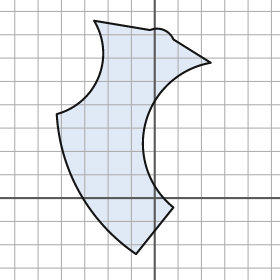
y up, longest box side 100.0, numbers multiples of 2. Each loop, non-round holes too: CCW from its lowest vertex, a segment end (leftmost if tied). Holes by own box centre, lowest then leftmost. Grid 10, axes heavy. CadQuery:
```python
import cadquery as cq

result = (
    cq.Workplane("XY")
    .moveTo(-8.0, -24.0)
    .lineTo(8.0, -4.0)
    .threePointArc((-4.0, 32.0), (24.0, 58.0))
    .lineTo(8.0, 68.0)
    .threePointArc((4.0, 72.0), (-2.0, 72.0))
    .lineTo(-26.0, 76.0)
    .threePointArc((-24.0, 52.0), (-42.0, 36.0))
    .threePointArc((-32.0, 2.0), (-8.0, -24.0))
    .close()
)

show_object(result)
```